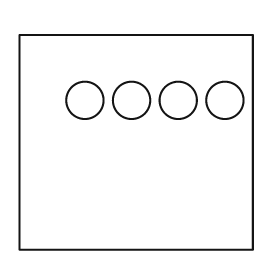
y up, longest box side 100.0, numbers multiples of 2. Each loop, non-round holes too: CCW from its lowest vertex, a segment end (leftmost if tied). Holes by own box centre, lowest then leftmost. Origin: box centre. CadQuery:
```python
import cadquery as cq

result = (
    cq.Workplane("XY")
    .moveTo(-50.0, -46.0)
    .lineTo(50.0, -46.0)
    .lineTo(50.0, 46.0)
    .lineTo(-50.0, 46.0)
    .close()
    .moveTo(-22.0, 18.0)
    .circle(8.0)
    .moveTo(-2.0, 18.0)
    .circle(8.0)
    .moveTo(18.0, 18.0)
    .circle(8.0)
    .moveTo(38.0, 18.0)
    .circle(8.0)
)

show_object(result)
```